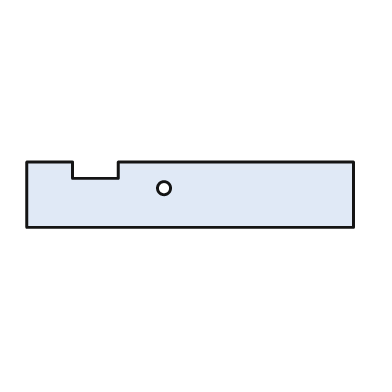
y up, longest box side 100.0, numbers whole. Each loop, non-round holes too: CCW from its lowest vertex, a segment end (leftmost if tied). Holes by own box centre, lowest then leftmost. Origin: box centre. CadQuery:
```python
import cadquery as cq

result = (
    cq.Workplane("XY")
    .moveTo(-50.0, -10.0)
    .lineTo(50.0, -10.0)
    .lineTo(50.0, 10.0)
    .lineTo(-22.0, 10.0)
    .lineTo(-22.0, 5.0)
    .lineTo(-36.0, 5.0)
    .lineTo(-36.0, 10.0)
    .lineTo(-50.0, 10.0)
    .close()
    .moveTo(-8.0, 2.0)
    .circle(2.0)
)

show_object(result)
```